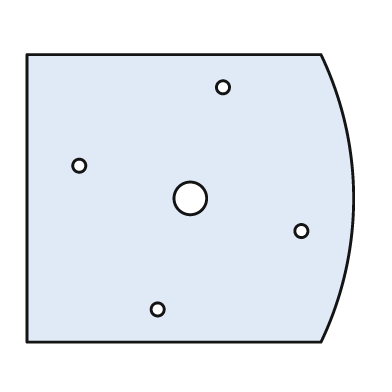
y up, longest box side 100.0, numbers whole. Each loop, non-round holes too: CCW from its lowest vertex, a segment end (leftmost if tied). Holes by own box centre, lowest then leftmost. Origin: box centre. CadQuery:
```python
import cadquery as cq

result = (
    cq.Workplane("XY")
    .moveTo(-50.0, -44.0)
    .lineTo(40.0, -44.0)
    .threePointArc((50.0, 0.0), (40.0, 44.0))
    .lineTo(-50.0, 44.0)
    .close()
    .moveTo(-10.0, -34.0)
    .circle(2.0)
    .moveTo(34.0, -10.0)
    .circle(2.0)
    .moveTo(0.0, 0.0)
    .circle(5.0)
    .moveTo(-34.0, 10.0)
    .circle(2.0)
    .moveTo(10.0, 34.0)
    .circle(2.0)
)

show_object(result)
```